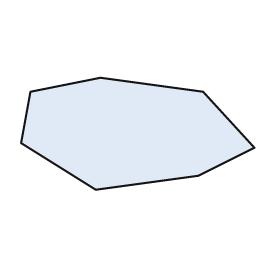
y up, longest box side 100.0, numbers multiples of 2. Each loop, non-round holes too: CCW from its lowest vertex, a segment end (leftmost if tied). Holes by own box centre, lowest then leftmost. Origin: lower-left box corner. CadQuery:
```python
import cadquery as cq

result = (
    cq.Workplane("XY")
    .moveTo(32.0, 0.0)
    .lineTo(76.0, 6.0)
    .lineTo(100.0, 18.0)
    .lineTo(78.0, 42.0)
    .lineTo(34.0, 48.0)
    .lineTo(4.0, 42.0)
    .lineTo(0.0, 20.0)
    .close()
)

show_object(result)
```